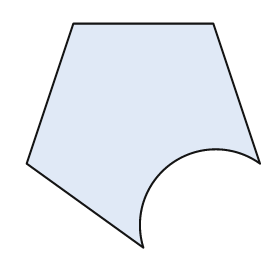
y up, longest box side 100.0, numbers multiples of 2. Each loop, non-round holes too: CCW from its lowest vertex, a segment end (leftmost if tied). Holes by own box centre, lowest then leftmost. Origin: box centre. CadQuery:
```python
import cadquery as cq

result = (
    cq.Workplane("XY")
    .moveTo(0.0, -48.0)
    .threePointArc((12.0, -12.0), (50.0, -12.0))
    .lineTo(30.0, 48.0)
    .lineTo(-30.0, 48.0)
    .lineTo(-50.0, -12.0)
    .close()
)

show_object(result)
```